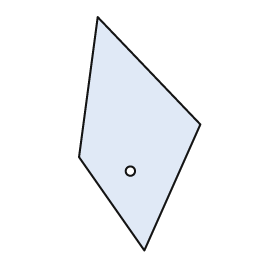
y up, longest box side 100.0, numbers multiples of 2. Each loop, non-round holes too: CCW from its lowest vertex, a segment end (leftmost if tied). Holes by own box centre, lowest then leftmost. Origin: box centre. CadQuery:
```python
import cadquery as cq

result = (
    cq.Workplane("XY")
    .moveTo(2.0, -50.0)
    .lineTo(26.0, 4.0)
    .lineTo(-18.0, 50.0)
    .lineTo(-26.0, -10.0)
    .close()
    .moveTo(-4.0, -16.0)
    .circle(2.0)
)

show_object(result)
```